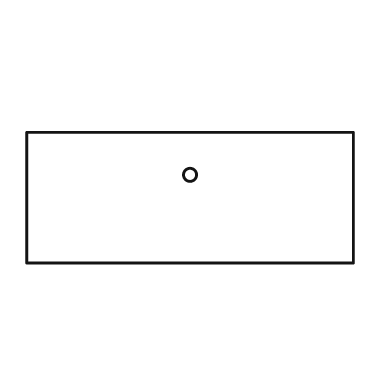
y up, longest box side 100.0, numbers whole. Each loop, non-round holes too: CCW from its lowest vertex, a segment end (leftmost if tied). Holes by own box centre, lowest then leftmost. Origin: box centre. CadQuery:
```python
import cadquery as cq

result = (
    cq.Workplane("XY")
    .moveTo(-50.0, -20.0)
    .lineTo(50.0, -20.0)
    .lineTo(50.0, 20.0)
    .lineTo(-50.0, 20.0)
    .close()
    .moveTo(0.0, 7.0)
    .circle(2.0)
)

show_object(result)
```